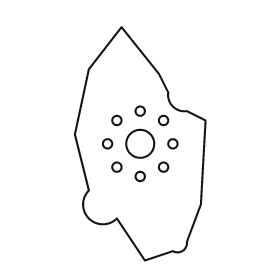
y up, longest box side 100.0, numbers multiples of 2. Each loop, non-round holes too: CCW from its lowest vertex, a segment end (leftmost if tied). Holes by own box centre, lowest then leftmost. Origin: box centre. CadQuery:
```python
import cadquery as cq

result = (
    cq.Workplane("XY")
    .moveTo(2.0, -50.0)
    .lineTo(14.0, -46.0)
    .threePointArc((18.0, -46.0), (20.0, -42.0))
    .lineTo(26.0, -26.0)
    .lineTo(28.0, 10.0)
    .lineTo(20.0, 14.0)
    .threePointArc((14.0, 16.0), (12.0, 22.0))
    .lineTo(8.0, 30.0)
    .lineTo(-8.0, 50.0)
    .lineTo(-22.0, 32.0)
    .lineTo(-28.0, 4.0)
    .lineTo(-22.0, -20.0)
    .threePointArc((-22.0, -32.0), (-10.0, -32.0))
    .close()
    .moveTo(0.0, -14.0)
    .circle(2.0)
    .moveTo(-10.0, -10.0)
    .circle(2.0)
    .moveTo(10.0, -10.0)
    .circle(2.0)
    .moveTo(-14.0, 0.0)
    .circle(2.0)
    .moveTo(0.0, 0.0)
    .circle(6.0)
    .moveTo(14.0, 0.0)
    .circle(2.0)
    .moveTo(-10.0, 10.0)
    .circle(2.0)
    .moveTo(10.0, 10.0)
    .circle(2.0)
    .moveTo(0.0, 14.0)
    .circle(2.0)
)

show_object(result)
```